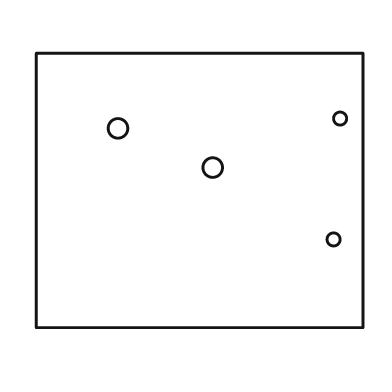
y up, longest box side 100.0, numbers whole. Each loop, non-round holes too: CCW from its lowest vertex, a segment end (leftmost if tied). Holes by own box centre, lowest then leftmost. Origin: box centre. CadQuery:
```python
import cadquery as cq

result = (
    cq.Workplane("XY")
    .moveTo(-50.0, -42.0)
    .lineTo(50.0, -42.0)
    .lineTo(50.0, 42.0)
    .lineTo(-50.0, 42.0)
    .close()
    .moveTo(41.0, -15.0)
    .circle(2.0)
    .moveTo(4.0, 7.0)
    .circle(3.0)
    .moveTo(-25.0, 19.0)
    .circle(3.0)
    .moveTo(43.0, 22.0)
    .circle(2.0)
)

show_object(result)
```